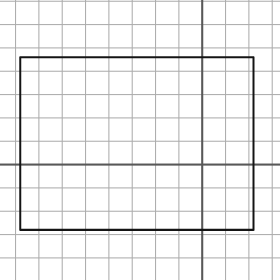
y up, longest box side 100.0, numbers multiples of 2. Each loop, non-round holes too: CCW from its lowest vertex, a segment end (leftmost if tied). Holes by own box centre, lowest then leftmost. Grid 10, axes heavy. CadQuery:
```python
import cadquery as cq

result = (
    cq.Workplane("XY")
    .moveTo(-78.0, -28.0)
    .lineTo(22.0, -28.0)
    .lineTo(22.0, 46.0)
    .lineTo(-78.0, 46.0)
    .close()
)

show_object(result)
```